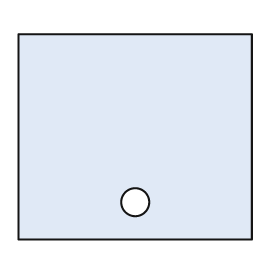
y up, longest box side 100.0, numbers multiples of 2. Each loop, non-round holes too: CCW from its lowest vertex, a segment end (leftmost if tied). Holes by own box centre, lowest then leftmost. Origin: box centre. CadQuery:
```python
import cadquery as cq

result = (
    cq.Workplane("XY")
    .moveTo(-50.0, -44.0)
    .lineTo(50.0, -44.0)
    .lineTo(50.0, 44.0)
    .lineTo(-50.0, 44.0)
    .close()
    .moveTo(0.0, -28.0)
    .circle(6.0)
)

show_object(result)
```